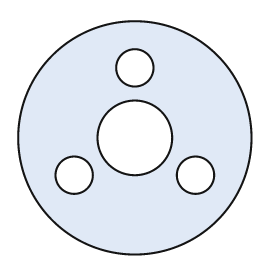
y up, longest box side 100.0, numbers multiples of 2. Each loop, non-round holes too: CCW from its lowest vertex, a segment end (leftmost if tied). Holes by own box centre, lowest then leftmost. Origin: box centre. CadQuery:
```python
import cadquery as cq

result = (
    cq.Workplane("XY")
    .moveTo(0.0, 0.0)
    .circle(50.0)
    .moveTo(-26.0, -16.0)
    .circle(8.0)
    .moveTo(26.0, -16.0)
    .circle(8.0)
    .moveTo(0.0, 0.0)
    .circle(16.0)
    .moveTo(0.0, 30.0)
    .circle(8.0)
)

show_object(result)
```